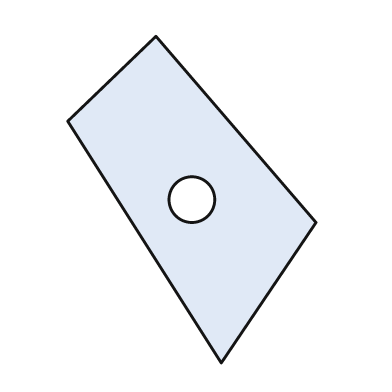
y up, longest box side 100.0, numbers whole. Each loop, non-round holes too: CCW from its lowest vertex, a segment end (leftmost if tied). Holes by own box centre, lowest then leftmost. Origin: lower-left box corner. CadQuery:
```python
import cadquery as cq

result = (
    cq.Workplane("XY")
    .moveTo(47.0, 0.0)
    .lineTo(76.0, 43.0)
    .lineTo(27.0, 100.0)
    .lineTo(0.0, 74.0)
    .close()
    .moveTo(38.0, 50.0)
    .circle(7.0)
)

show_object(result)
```